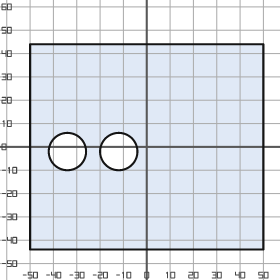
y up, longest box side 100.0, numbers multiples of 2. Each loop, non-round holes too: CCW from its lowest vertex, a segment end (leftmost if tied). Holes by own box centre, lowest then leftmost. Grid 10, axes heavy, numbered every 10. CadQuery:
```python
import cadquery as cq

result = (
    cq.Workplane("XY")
    .moveTo(-50.0, -44.0)
    .lineTo(50.0, -44.0)
    .lineTo(50.0, 44.0)
    .lineTo(-50.0, 44.0)
    .close()
    .moveTo(-34.0, -2.0)
    .circle(8.0)
    .moveTo(-12.0, -2.0)
    .circle(8.0)
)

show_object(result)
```